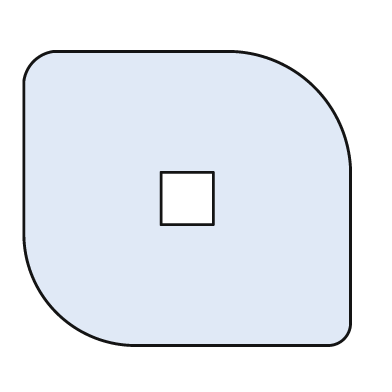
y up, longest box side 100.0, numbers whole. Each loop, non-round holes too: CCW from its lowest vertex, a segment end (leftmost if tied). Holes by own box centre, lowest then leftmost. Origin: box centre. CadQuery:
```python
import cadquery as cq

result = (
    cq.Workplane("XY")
    .moveTo(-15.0, -45.0)
    .lineTo(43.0, -45.0)
    .threePointArc((48.0, -43.0), (50.0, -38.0))
    .lineTo(50.0, 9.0)
    .threePointArc((39.0, 34.0), (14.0, 45.0))
    .lineTo(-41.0, 45.0)
    .threePointArc((-47.0, 42.0), (-50.0, 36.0))
    .lineTo(-50.0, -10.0)
    .threePointArc((-40.0, -35.0), (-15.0, -45.0))
    .close()
    .moveTo(-8.0, -8.0)
    .lineTo(8.0, -8.0)
    .lineTo(8.0, 8.0)
    .lineTo(-8.0, 8.0)
    .close()
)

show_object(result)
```